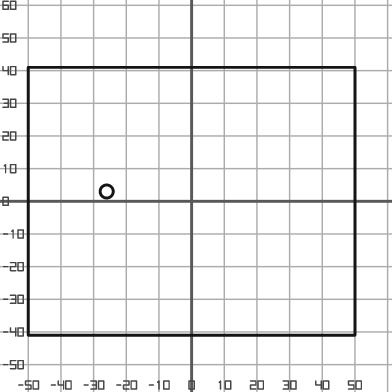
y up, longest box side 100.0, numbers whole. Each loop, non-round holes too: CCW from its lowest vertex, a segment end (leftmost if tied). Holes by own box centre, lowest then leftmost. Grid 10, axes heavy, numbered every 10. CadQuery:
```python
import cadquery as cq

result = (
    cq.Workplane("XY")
    .moveTo(-50.0, -41.0)
    .lineTo(50.0, -41.0)
    .lineTo(50.0, 41.0)
    .lineTo(-50.0, 41.0)
    .close()
    .moveTo(-26.0, 3.0)
    .circle(2.0)
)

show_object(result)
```